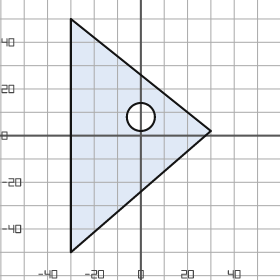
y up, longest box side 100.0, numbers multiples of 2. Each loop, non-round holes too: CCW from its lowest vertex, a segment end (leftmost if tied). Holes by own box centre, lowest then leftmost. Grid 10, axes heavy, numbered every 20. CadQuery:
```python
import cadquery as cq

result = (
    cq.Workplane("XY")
    .moveTo(-30.0, -50.0)
    .lineTo(30.0, 2.0)
    .lineTo(-30.0, 50.0)
    .close()
    .moveTo(0.0, 8.0)
    .circle(6.0)
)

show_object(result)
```